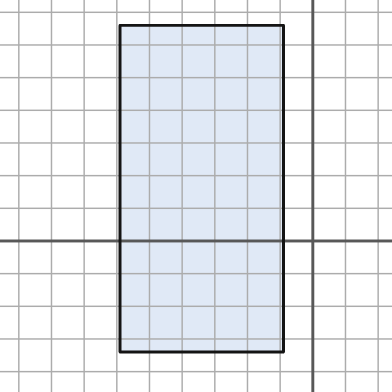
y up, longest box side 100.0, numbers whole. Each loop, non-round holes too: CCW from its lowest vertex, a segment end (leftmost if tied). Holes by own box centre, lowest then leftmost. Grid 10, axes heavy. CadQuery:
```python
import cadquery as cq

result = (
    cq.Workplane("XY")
    .moveTo(-59.0, -34.0)
    .lineTo(-9.0, -34.0)
    .lineTo(-9.0, 66.0)
    .lineTo(-59.0, 66.0)
    .close()
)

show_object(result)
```